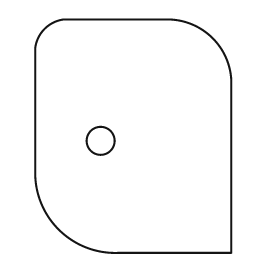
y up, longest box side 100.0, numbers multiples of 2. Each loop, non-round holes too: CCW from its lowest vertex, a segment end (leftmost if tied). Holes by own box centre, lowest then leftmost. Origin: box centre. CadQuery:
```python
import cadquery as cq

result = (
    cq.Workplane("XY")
    .moveTo(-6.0, -50.0)
    .lineTo(42.0, -50.0)
    .lineTo(42.0, 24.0)
    .threePointArc((34.0, 42.0), (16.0, 50.0))
    .lineTo(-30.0, 50.0)
    .threePointArc((-38.0, 46.0), (-42.0, 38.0))
    .lineTo(-42.0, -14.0)
    .threePointArc((-32.0, -40.0), (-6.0, -50.0))
    .close()
    .moveTo(-14.0, -2.0)
    .circle(6.0)
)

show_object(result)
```